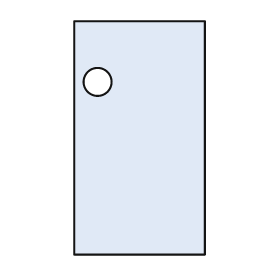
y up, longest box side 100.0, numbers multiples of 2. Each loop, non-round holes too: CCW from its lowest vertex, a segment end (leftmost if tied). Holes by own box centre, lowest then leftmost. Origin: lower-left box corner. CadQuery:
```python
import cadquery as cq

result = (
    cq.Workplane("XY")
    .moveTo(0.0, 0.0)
    .lineTo(56.0, 0.0)
    .lineTo(56.0, 100.0)
    .lineTo(0.0, 100.0)
    .close()
    .moveTo(10.0, 74.0)
    .circle(6.0)
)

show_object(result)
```